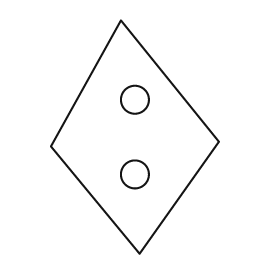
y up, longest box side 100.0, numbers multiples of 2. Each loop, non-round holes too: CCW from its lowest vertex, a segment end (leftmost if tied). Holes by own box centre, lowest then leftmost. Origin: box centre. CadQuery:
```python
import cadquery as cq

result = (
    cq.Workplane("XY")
    .moveTo(2.0, -50.0)
    .lineTo(36.0, -2.0)
    .lineTo(-6.0, 50.0)
    .lineTo(-36.0, -4.0)
    .close()
    .moveTo(0.0, -16.0)
    .circle(6.0)
    .moveTo(0.0, 16.0)
    .circle(6.0)
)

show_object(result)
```